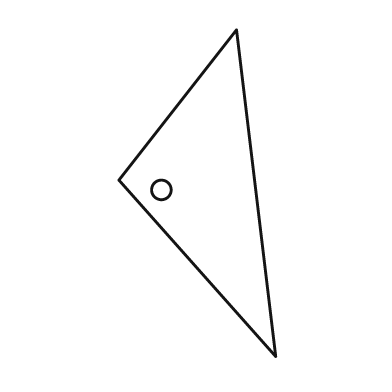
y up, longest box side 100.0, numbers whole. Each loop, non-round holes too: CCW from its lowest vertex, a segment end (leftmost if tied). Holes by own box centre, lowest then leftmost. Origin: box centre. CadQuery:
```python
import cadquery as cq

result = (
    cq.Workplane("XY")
    .moveTo(24.0, -50.0)
    .lineTo(12.0, 50.0)
    .lineTo(-24.0, 4.0)
    .close()
    .moveTo(-11.0, 1.0)
    .circle(3.0)
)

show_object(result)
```